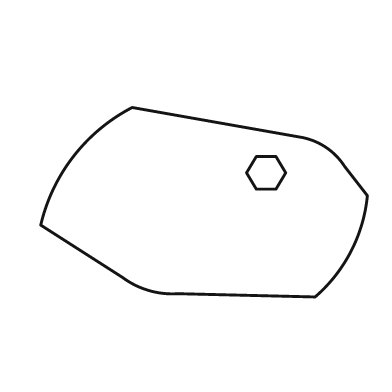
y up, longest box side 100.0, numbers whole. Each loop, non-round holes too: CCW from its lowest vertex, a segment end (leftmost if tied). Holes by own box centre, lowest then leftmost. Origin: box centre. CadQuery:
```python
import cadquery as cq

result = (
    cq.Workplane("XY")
    .moveTo(34.0, -29.0)
    .threePointArc((45.0, -15.0), (50.0, 2.0))
    .lineTo(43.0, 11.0)
    .threePointArc((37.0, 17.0), (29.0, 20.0))
    .lineTo(-22.0, 29.0)
    .threePointArc((-40.0, 14.0), (-50.0, -7.0))
    .lineTo(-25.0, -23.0)
    .threePointArc((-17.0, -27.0), (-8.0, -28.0))
    .close()
    .moveTo(16.0, 4.0)
    .lineTo(22.0, 4.0)
    .lineTo(25.0, 9.0)
    .lineTo(22.0, 14.0)
    .lineTo(16.0, 14.0)
    .lineTo(13.0, 9.0)
    .close()
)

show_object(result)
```